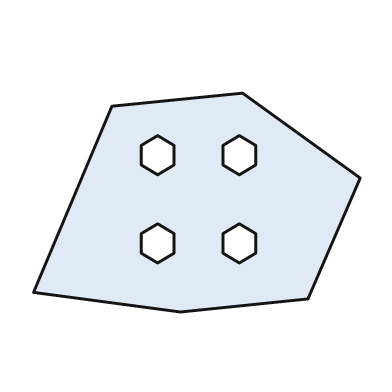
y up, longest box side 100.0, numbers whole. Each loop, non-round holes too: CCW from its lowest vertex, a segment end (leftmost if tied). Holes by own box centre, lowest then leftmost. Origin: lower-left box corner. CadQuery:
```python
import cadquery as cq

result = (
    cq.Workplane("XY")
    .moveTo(45.0, 0.0)
    .lineTo(84.0, 4.0)
    .lineTo(100.0, 41.0)
    .lineTo(64.0, 67.0)
    .lineTo(24.0, 63.0)
    .lineTo(0.0, 6.0)
    .close()
    .moveTo(38.0, 15.0)
    .lineTo(43.0, 18.0)
    .lineTo(43.0, 24.0)
    .lineTo(38.0, 27.0)
    .lineTo(33.0, 24.0)
    .lineTo(33.0, 18.0)
    .close()
    .moveTo(63.0, 15.0)
    .lineTo(68.0, 18.0)
    .lineTo(68.0, 24.0)
    .lineTo(63.0, 27.0)
    .lineTo(58.0, 24.0)
    .lineTo(58.0, 18.0)
    .close()
    .moveTo(38.0, 42.0)
    .lineTo(43.0, 45.0)
    .lineTo(43.0, 51.0)
    .lineTo(38.0, 54.0)
    .lineTo(33.0, 51.0)
    .lineTo(33.0, 45.0)
    .close()
    .moveTo(63.0, 42.0)
    .lineTo(68.0, 45.0)
    .lineTo(68.0, 51.0)
    .lineTo(63.0, 54.0)
    .lineTo(58.0, 51.0)
    .lineTo(58.0, 45.0)
    .close()
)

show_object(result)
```